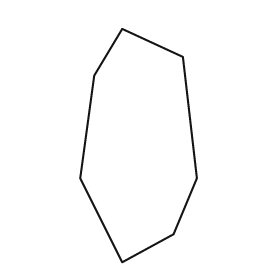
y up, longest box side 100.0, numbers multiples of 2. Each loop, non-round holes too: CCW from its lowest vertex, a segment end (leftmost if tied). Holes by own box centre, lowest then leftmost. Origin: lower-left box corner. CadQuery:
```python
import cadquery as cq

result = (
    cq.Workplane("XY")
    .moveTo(18.0, 0.0)
    .lineTo(40.0, 12.0)
    .lineTo(50.0, 36.0)
    .lineTo(44.0, 88.0)
    .lineTo(18.0, 100.0)
    .lineTo(6.0, 80.0)
    .lineTo(0.0, 36.0)
    .close()
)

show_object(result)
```